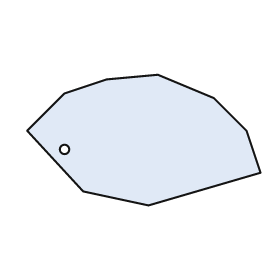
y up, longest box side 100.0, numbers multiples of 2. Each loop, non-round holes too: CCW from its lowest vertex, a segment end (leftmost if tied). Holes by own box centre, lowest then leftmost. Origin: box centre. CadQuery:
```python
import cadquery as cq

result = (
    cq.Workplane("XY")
    .moveTo(2.0, -28.0)
    .lineTo(50.0, -14.0)
    .lineTo(44.0, 4.0)
    .lineTo(30.0, 18.0)
    .lineTo(6.0, 28.0)
    .lineTo(-16.0, 26.0)
    .lineTo(-34.0, 20.0)
    .lineTo(-50.0, 4.0)
    .lineTo(-26.0, -22.0)
    .close()
    .moveTo(-34.0, -4.0)
    .circle(2.0)
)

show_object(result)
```